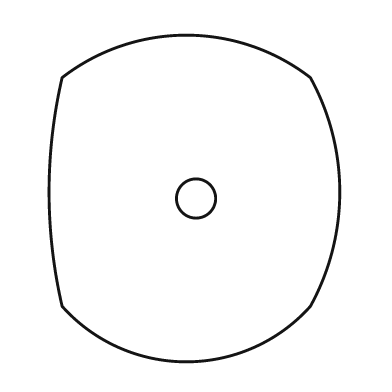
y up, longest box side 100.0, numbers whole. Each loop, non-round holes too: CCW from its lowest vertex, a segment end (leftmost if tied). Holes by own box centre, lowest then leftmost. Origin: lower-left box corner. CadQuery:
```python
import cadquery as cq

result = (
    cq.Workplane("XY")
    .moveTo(4.0, 17.0)
    .threePointArc((42.0, 0.0), (80.0, 17.0))
    .threePointArc((89.0, 52.0), (80.0, 87.0))
    .threePointArc((42.0, 100.0), (4.0, 87.0))
    .threePointArc((0.0, 52.0), (4.0, 17.0))
    .close()
    .moveTo(45.0, 50.0)
    .circle(6.0)
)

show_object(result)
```